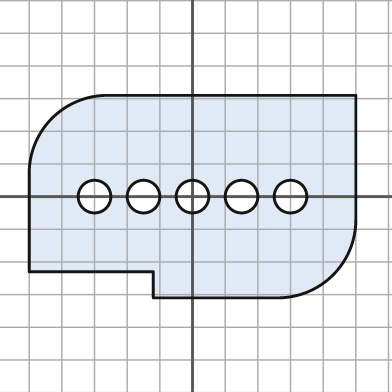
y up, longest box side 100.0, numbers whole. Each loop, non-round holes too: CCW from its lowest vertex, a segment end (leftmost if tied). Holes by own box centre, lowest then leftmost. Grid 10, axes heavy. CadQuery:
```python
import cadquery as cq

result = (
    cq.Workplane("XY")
    .moveTo(-12.0, -31.0)
    .lineTo(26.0, -31.0)
    .threePointArc((43.0, -24.0), (50.0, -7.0))
    .lineTo(50.0, 31.0)
    .lineTo(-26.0, 31.0)
    .threePointArc((-43.0, 24.0), (-50.0, 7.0))
    .lineTo(-50.0, -23.0)
    .lineTo(-12.0, -23.0)
    .close()
    .moveTo(-30.0, 0.0)
    .circle(5.0)
    .moveTo(-15.0, 0.0)
    .circle(5.0)
    .moveTo(0.0, 0.0)
    .circle(5.0)
    .moveTo(15.0, 0.0)
    .circle(5.0)
    .moveTo(30.0, 0.0)
    .circle(5.0)
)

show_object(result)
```